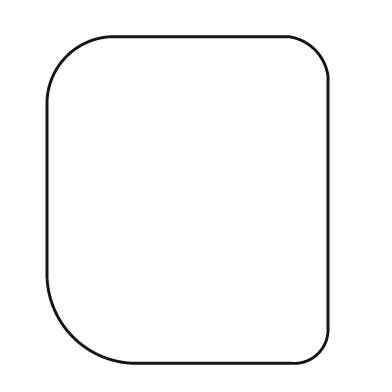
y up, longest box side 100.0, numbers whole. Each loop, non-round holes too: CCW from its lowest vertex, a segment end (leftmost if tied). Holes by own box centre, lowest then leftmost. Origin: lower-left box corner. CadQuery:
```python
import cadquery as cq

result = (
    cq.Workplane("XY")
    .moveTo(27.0, 0.0)
    .lineTo(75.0, 0.0)
    .threePointArc((83.0, 3.0), (86.0, 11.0))
    .lineTo(86.0, 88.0)
    .threePointArc((82.0, 96.0), (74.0, 100.0))
    .lineTo(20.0, 100.0)
    .threePointArc((6.0, 94.0), (0.0, 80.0))
    .lineTo(0.0, 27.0)
    .threePointArc((8.0, 8.0), (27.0, 0.0))
    .close()
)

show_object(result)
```